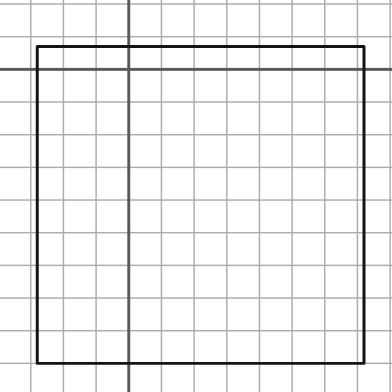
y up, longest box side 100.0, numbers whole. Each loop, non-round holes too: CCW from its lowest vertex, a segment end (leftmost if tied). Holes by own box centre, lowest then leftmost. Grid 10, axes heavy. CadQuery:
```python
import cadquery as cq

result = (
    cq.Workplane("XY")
    .moveTo(-28.0, -90.0)
    .lineTo(72.0, -90.0)
    .lineTo(72.0, 7.0)
    .lineTo(-28.0, 7.0)
    .close()
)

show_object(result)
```